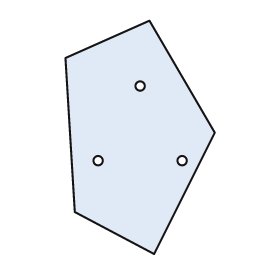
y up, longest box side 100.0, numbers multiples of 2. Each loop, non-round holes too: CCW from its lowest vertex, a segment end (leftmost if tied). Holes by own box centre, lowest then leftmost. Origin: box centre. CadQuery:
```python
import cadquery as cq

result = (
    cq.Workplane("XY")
    .moveTo(6.0, -50.0)
    .lineTo(32.0, 2.0)
    .lineTo(4.0, 50.0)
    .lineTo(-32.0, 34.0)
    .lineTo(-28.0, -32.0)
    .close()
    .moveTo(-18.0, -10.0)
    .circle(2.0)
    .moveTo(18.0, -10.0)
    .circle(2.0)
    .moveTo(0.0, 22.0)
    .circle(2.0)
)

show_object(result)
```